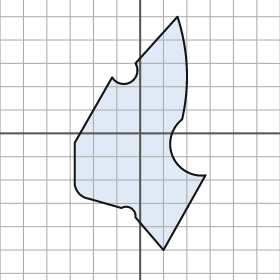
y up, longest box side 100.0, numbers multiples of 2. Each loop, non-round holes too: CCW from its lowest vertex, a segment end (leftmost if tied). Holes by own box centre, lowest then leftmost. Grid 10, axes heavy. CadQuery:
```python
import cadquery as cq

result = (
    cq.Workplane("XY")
    .moveTo(10.0, -50.0)
    .lineTo(28.0, -18.0)
    .threePointArc((14.0, -10.0), (18.0, 6.0))
    .threePointArc((20.0, 28.0), (16.0, 50.0))
    .lineTo(-2.0, 30.0)
    .threePointArc((-4.0, 22.0), (-12.0, 24.0))
    .lineTo(-28.0, -4.0)
    .lineTo(-28.0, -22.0)
    .threePointArc((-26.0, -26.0), (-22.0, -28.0))
    .lineTo(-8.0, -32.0)
    .threePointArc((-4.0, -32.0), (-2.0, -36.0))
    .close()
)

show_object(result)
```